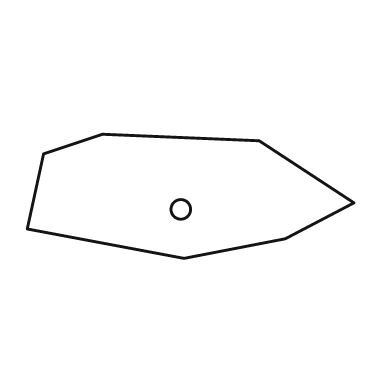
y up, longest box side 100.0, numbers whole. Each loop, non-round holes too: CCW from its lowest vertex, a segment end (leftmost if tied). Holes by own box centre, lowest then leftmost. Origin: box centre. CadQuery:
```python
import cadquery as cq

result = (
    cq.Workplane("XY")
    .moveTo(-2.0, -19.0)
    .lineTo(29.0, -13.0)
    .lineTo(50.0, -2.0)
    .lineTo(21.0, 17.0)
    .lineTo(-27.0, 19.0)
    .lineTo(-45.0, 13.0)
    .lineTo(-50.0, -10.0)
    .close()
    .moveTo(-3.0, -4.0)
    .circle(3.0)
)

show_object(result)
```